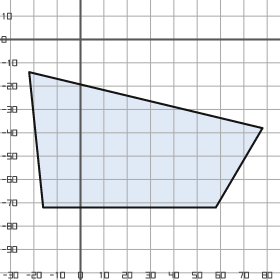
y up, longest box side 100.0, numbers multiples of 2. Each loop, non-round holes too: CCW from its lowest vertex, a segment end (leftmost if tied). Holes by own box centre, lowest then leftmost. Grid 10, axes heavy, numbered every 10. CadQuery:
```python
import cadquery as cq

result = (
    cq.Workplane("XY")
    .moveTo(-16.0, -72.0)
    .lineTo(58.0, -72.0)
    .lineTo(78.0, -38.0)
    .lineTo(-22.0, -14.0)
    .close()
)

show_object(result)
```